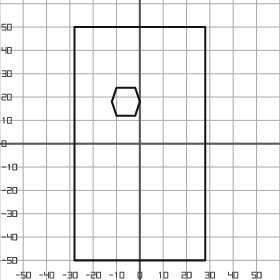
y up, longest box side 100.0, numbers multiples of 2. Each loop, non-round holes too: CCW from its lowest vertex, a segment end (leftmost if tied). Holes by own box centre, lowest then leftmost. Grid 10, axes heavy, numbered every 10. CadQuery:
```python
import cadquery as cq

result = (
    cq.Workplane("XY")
    .moveTo(-28.0, -50.0)
    .lineTo(28.0, -50.0)
    .lineTo(28.0, 50.0)
    .lineTo(-28.0, 50.0)
    .close()
    .moveTo(-10.0, 12.0)
    .lineTo(-2.0, 12.0)
    .lineTo(0.0, 18.0)
    .lineTo(-2.0, 24.0)
    .lineTo(-10.0, 24.0)
    .lineTo(-12.0, 18.0)
    .close()
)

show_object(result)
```